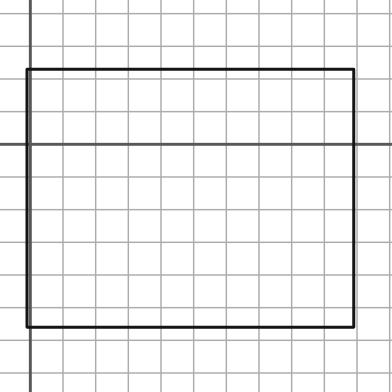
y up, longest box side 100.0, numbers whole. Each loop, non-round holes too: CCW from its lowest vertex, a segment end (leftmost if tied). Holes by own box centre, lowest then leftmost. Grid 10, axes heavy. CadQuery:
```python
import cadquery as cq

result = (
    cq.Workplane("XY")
    .moveTo(-1.0, -56.0)
    .lineTo(99.0, -56.0)
    .lineTo(99.0, 23.0)
    .lineTo(-1.0, 23.0)
    .close()
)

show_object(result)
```